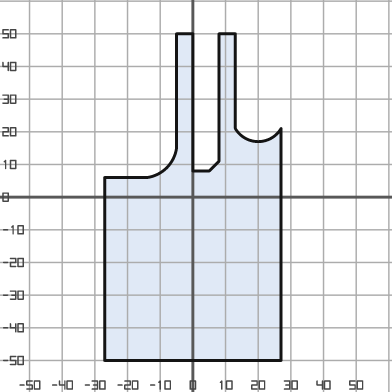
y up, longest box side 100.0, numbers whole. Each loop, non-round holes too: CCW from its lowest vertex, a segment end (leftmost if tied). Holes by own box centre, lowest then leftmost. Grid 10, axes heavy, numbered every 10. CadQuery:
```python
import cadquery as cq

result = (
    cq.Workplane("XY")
    .moveTo(-27.0, -50.0)
    .lineTo(27.0, -50.0)
    .lineTo(27.0, 21.0)
    .threePointArc((20.0, 17.0), (13.0, 21.0))
    .lineTo(13.0, 50.0)
    .lineTo(8.0, 50.0)
    .lineTo(8.0, 11.0)
    .lineTo(5.0, 8.0)
    .lineTo(0.0, 8.0)
    .lineTo(0.0, 50.0)
    .lineTo(-5.0, 50.0)
    .lineTo(-5.0, 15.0)
    .threePointArc((-8.0, 9.0), (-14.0, 6.0))
    .lineTo(-27.0, 6.0)
    .close()
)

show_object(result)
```